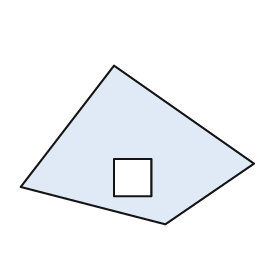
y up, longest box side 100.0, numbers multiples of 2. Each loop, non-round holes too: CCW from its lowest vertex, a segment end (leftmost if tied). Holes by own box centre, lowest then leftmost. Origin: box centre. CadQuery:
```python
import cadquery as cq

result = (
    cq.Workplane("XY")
    .moveTo(12.0, -34.0)
    .lineTo(50.0, -8.0)
    .lineTo(-10.0, 34.0)
    .lineTo(-50.0, -18.0)
    .close()
    .moveTo(-10.0, -22.0)
    .lineTo(6.0, -22.0)
    .lineTo(6.0, -6.0)
    .lineTo(-10.0, -6.0)
    .close()
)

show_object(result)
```